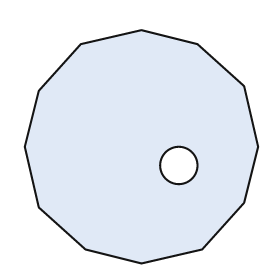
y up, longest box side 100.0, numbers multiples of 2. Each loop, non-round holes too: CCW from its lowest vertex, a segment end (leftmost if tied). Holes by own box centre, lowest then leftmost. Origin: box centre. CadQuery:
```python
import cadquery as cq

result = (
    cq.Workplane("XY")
    .moveTo(0.0, -50.0)
    .lineTo(26.0, -44.0)
    .lineTo(44.0, -24.0)
    .lineTo(50.0, 0.0)
    .lineTo(44.0, 26.0)
    .lineTo(24.0, 44.0)
    .lineTo(0.0, 50.0)
    .lineTo(-26.0, 44.0)
    .lineTo(-44.0, 24.0)
    .lineTo(-50.0, 0.0)
    .lineTo(-44.0, -26.0)
    .lineTo(-24.0, -44.0)
    .close()
    .moveTo(16.0, -8.0)
    .circle(8.0)
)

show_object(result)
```